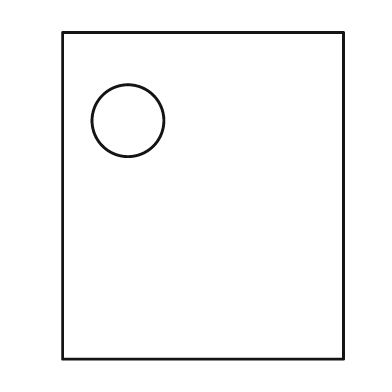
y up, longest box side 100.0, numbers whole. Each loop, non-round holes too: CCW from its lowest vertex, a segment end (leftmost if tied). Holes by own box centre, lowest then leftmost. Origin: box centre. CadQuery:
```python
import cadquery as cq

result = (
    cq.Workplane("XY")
    .moveTo(-43.0, -50.0)
    .lineTo(43.0, -50.0)
    .lineTo(43.0, 50.0)
    .lineTo(-43.0, 50.0)
    .close()
    .moveTo(-23.0, 23.0)
    .circle(11.0)
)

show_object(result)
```